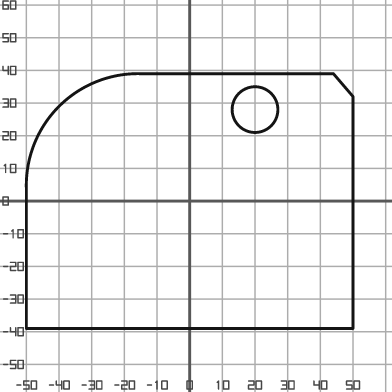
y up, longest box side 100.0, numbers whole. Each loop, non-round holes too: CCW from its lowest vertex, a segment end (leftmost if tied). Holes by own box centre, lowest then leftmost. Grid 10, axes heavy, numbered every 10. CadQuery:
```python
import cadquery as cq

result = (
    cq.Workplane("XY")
    .moveTo(-50.0, -39.0)
    .lineTo(50.0, -39.0)
    .lineTo(50.0, 32.0)
    .lineTo(44.0, 39.0)
    .lineTo(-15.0, 39.0)
    .threePointArc((-40.0, 29.0), (-50.0, 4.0))
    .close()
    .moveTo(20.0, 28.0)
    .circle(7.0)
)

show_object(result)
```